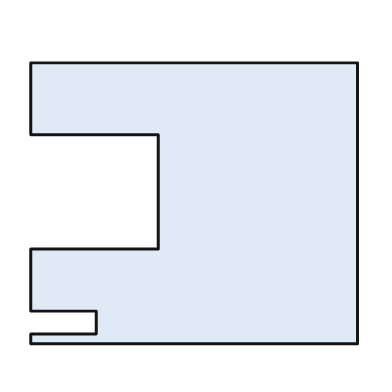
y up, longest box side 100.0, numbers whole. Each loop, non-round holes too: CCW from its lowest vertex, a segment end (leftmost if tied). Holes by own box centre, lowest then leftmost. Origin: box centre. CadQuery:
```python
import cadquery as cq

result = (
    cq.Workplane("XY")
    .moveTo(-50.0, -43.0)
    .lineTo(50.0, -43.0)
    .lineTo(50.0, 43.0)
    .lineTo(-50.0, 43.0)
    .lineTo(-50.0, 21.0)
    .lineTo(-11.0, 21.0)
    .lineTo(-11.0, -14.0)
    .lineTo(-50.0, -14.0)
    .lineTo(-50.0, -33.0)
    .lineTo(-30.0, -33.0)
    .lineTo(-30.0, -40.0)
    .lineTo(-50.0, -40.0)
    .close()
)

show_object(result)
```